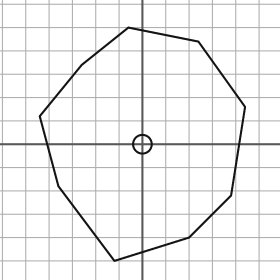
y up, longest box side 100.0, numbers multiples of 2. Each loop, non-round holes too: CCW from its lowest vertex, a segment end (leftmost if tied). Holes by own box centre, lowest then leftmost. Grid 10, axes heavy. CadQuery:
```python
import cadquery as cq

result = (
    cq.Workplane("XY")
    .moveTo(-12.0, -50.0)
    .lineTo(20.0, -40.0)
    .lineTo(38.0, -22.0)
    .lineTo(44.0, 16.0)
    .lineTo(24.0, 44.0)
    .lineTo(-6.0, 50.0)
    .lineTo(-26.0, 34.0)
    .lineTo(-44.0, 12.0)
    .lineTo(-36.0, -18.0)
    .close()
    .moveTo(0.0, 0.0)
    .circle(4.0)
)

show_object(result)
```